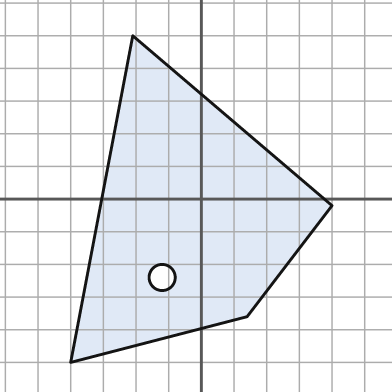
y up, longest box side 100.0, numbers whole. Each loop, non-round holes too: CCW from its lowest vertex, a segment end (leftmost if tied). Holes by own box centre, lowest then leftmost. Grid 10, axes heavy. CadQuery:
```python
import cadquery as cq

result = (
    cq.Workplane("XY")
    .moveTo(-40.0, -50.0)
    .lineTo(14.0, -36.0)
    .lineTo(40.0, -2.0)
    .lineTo(-21.0, 50.0)
    .close()
    .moveTo(-12.0, -24.0)
    .circle(4.0)
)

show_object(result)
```